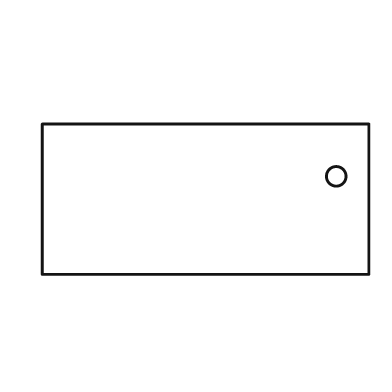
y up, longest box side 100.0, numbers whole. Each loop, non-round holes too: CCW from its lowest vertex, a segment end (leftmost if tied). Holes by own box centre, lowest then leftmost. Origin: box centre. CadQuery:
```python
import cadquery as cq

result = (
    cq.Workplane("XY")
    .moveTo(-50.0, -23.0)
    .lineTo(50.0, -23.0)
    .lineTo(50.0, 23.0)
    .lineTo(-50.0, 23.0)
    .close()
    .moveTo(40.0, 7.0)
    .circle(3.0)
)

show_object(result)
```